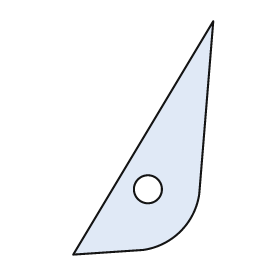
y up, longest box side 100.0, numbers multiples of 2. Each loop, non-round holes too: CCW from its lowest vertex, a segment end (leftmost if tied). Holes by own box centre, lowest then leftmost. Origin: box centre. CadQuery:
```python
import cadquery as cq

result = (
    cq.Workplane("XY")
    .moveTo(-30.0, -50.0)
    .lineTo(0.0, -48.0)
    .threePointArc((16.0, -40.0), (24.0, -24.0))
    .lineTo(30.0, 50.0)
    .close()
    .moveTo(2.0, -22.0)
    .circle(6.0)
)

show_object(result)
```